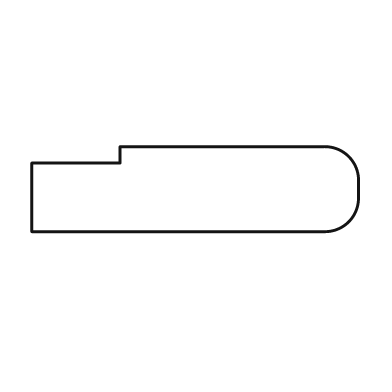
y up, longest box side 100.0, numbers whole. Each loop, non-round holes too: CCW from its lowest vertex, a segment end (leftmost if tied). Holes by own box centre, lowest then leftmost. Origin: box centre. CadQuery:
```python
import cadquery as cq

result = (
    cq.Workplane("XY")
    .moveTo(-50.0, -13.0)
    .lineTo(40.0, -13.0)
    .threePointArc((47.0, -10.0), (50.0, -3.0))
    .lineTo(50.0, 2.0)
    .threePointArc((47.0, 10.0), (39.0, 13.0))
    .lineTo(-23.0, 13.0)
    .lineTo(-23.0, 8.0)
    .lineTo(-50.0, 8.0)
    .close()
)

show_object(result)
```